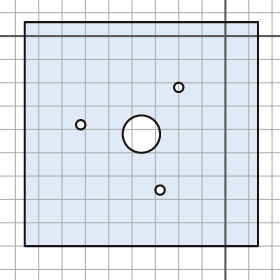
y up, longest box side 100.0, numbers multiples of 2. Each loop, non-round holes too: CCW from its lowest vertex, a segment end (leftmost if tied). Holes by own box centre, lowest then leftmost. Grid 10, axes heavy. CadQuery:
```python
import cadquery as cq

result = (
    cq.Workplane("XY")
    .moveTo(-86.0, -90.0)
    .lineTo(14.0, -90.0)
    .lineTo(14.0, 6.0)
    .lineTo(-86.0, 6.0)
    .close()
    .moveTo(-28.0, -66.0)
    .circle(2.0)
    .moveTo(-36.0, -42.0)
    .circle(8.0)
    .moveTo(-62.0, -38.0)
    .circle(2.0)
    .moveTo(-20.0, -22.0)
    .circle(2.0)
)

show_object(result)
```